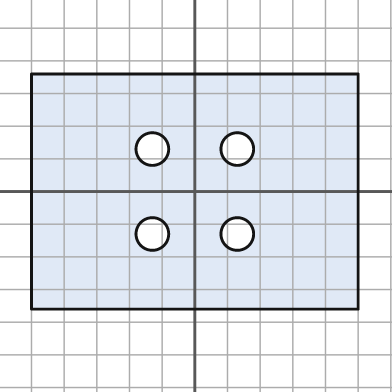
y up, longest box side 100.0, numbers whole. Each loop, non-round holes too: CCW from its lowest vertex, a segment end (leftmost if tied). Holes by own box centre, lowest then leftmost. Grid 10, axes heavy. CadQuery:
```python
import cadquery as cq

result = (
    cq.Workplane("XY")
    .moveTo(-50.0, -36.0)
    .lineTo(50.0, -36.0)
    .lineTo(50.0, 36.0)
    .lineTo(-50.0, 36.0)
    .close()
    .moveTo(-13.0, -13.0)
    .circle(5.0)
    .moveTo(13.0, -13.0)
    .circle(5.0)
    .moveTo(-13.0, 13.0)
    .circle(5.0)
    .moveTo(13.0, 13.0)
    .circle(5.0)
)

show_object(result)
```